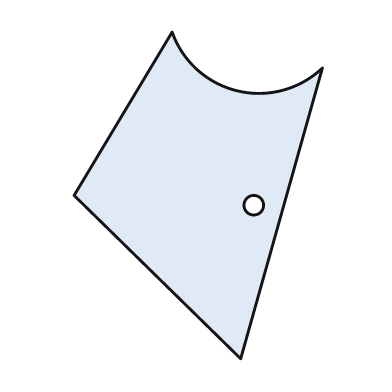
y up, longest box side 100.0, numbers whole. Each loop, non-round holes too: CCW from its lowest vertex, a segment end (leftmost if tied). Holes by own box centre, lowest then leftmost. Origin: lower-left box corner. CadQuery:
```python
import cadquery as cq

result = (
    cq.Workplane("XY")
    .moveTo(51.0, 0.0)
    .lineTo(76.0, 89.0)
    .threePointArc((50.0, 82.0), (30.0, 100.0))
    .lineTo(0.0, 50.0)
    .close()
    .moveTo(55.0, 47.0)
    .circle(3.0)
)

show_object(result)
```